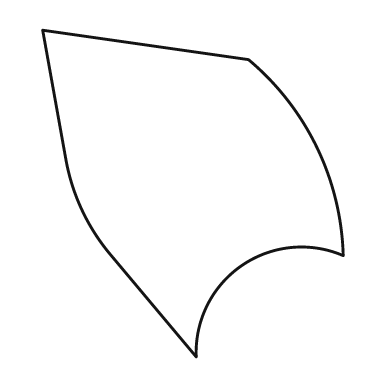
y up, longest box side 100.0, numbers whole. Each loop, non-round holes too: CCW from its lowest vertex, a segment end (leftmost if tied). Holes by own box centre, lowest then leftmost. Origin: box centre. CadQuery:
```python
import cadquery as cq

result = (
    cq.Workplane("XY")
    .moveTo(1.0, -50.0)
    .threePointArc((15.0, -22.0), (46.0, -19.0))
    .threePointArc((38.0, 14.0), (17.0, 41.0))
    .lineTo(-46.0, 50.0)
    .lineTo(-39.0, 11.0)
    .threePointArc((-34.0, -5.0), (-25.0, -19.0))
    .close()
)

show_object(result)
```